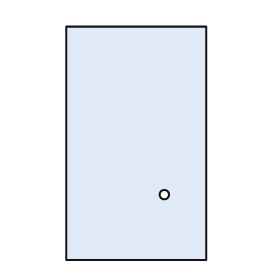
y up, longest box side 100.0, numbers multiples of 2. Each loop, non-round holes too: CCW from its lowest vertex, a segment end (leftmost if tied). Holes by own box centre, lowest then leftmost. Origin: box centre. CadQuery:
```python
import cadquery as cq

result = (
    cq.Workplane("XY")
    .moveTo(-30.0, -50.0)
    .lineTo(30.0, -50.0)
    .lineTo(30.0, 50.0)
    .lineTo(-30.0, 50.0)
    .close()
    .moveTo(12.0, -22.0)
    .circle(2.0)
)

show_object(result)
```